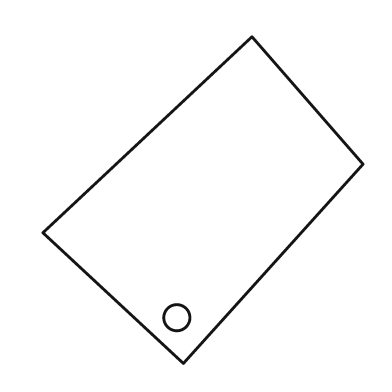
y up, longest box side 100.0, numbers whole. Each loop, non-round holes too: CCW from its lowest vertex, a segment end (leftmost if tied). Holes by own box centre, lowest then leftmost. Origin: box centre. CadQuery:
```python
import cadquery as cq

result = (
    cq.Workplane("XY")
    .moveTo(-6.0, -50.0)
    .lineTo(49.0, 11.0)
    .lineTo(15.0, 50.0)
    .lineTo(-49.0, -10.0)
    .close()
    .moveTo(-8.0, -36.0)
    .circle(4.0)
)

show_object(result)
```